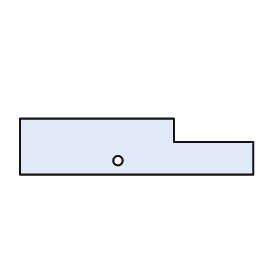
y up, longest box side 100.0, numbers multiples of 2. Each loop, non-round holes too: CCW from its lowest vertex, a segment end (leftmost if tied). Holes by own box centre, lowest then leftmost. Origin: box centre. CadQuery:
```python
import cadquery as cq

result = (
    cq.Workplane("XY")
    .moveTo(-50.0, -12.0)
    .lineTo(50.0, -12.0)
    .lineTo(50.0, 2.0)
    .lineTo(16.0, 2.0)
    .lineTo(16.0, 12.0)
    .lineTo(-50.0, 12.0)
    .close()
    .moveTo(-8.0, -6.0)
    .circle(2.0)
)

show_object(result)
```